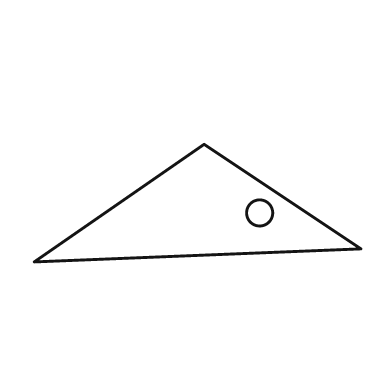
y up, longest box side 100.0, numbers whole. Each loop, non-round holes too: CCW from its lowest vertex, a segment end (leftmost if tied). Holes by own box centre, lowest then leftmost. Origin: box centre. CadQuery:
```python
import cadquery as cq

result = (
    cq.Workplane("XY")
    .moveTo(-50.0, -18.0)
    .lineTo(50.0, -14.0)
    .lineTo(2.0, 18.0)
    .close()
    .moveTo(19.0, -3.0)
    .circle(4.0)
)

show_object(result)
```